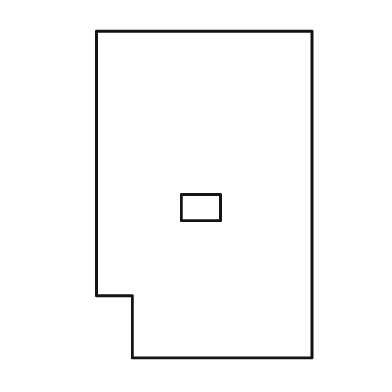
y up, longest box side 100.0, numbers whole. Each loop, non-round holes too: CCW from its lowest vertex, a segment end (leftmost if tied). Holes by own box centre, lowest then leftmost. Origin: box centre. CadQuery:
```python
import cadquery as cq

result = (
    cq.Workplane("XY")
    .moveTo(-22.0, -50.0)
    .lineTo(33.0, -50.0)
    .lineTo(33.0, 50.0)
    .lineTo(-33.0, 50.0)
    .lineTo(-33.0, -31.0)
    .lineTo(-22.0, -31.0)
    .close()
    .moveTo(-7.0, -8.0)
    .lineTo(5.0, -8.0)
    .lineTo(5.0, 0.0)
    .lineTo(-7.0, 0.0)
    .close()
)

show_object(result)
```